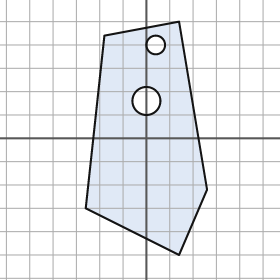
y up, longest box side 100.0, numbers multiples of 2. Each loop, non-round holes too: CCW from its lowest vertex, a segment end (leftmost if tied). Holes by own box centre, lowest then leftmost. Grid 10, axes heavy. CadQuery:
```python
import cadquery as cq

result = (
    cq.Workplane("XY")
    .moveTo(14.0, -50.0)
    .lineTo(26.0, -22.0)
    .lineTo(14.0, 50.0)
    .lineTo(-18.0, 44.0)
    .lineTo(-26.0, -30.0)
    .close()
    .moveTo(0.0, 16.0)
    .circle(6.0)
    .moveTo(4.0, 40.0)
    .circle(4.0)
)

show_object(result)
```